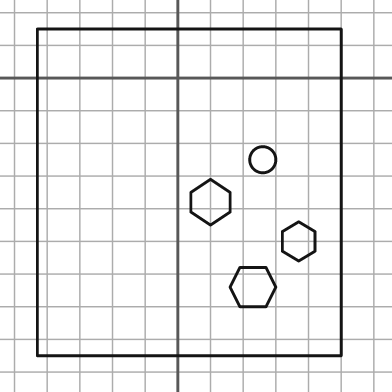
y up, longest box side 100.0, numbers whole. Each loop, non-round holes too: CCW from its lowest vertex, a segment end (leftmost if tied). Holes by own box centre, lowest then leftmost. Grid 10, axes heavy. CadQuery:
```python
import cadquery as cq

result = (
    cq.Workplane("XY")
    .moveTo(-43.0, -85.0)
    .lineTo(50.0, -85.0)
    .lineTo(50.0, 15.0)
    .lineTo(-43.0, 15.0)
    .close()
    .moveTo(19.0, -70.0)
    .lineTo(27.0, -70.0)
    .lineTo(30.0, -64.0)
    .lineTo(27.0, -58.0)
    .lineTo(19.0, -58.0)
    .lineTo(16.0, -64.0)
    .close()
    .moveTo(37.0, -56.0)
    .lineTo(42.0, -53.0)
    .lineTo(42.0, -47.0)
    .lineTo(37.0, -44.0)
    .lineTo(32.0, -47.0)
    .lineTo(32.0, -53.0)
    .close()
    .moveTo(10.0, -45.0)
    .lineTo(16.0, -41.0)
    .lineTo(16.0, -35.0)
    .lineTo(10.0, -31.0)
    .lineTo(4.0, -35.0)
    .lineTo(4.0, -41.0)
    .close()
    .moveTo(26.0, -25.0)
    .circle(4.0)
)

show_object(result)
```